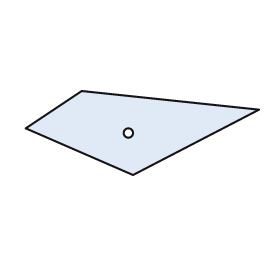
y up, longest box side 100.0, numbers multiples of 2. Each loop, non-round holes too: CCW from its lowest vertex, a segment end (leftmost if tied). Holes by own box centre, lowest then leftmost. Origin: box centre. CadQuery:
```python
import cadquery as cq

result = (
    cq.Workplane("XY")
    .moveTo(-4.0, -18.0)
    .lineTo(50.0, 10.0)
    .lineTo(-26.0, 18.0)
    .lineTo(-50.0, 2.0)
    .close()
    .moveTo(-6.0, 0.0)
    .circle(2.0)
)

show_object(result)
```